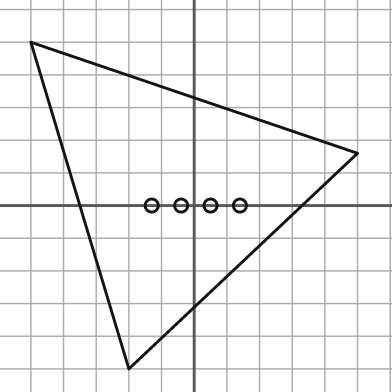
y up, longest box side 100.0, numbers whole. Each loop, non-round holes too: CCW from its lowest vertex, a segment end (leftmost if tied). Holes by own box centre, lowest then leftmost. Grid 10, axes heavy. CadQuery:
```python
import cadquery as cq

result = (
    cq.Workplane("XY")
    .moveTo(-20.0, -50.0)
    .lineTo(50.0, 16.0)
    .lineTo(-50.0, 50.0)
    .close()
    .moveTo(-13.0, 0.0)
    .circle(2.0)
    .moveTo(-4.0, 0.0)
    .circle(2.0)
    .moveTo(5.0, 0.0)
    .circle(2.0)
    .moveTo(14.0, 0.0)
    .circle(2.0)
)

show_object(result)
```